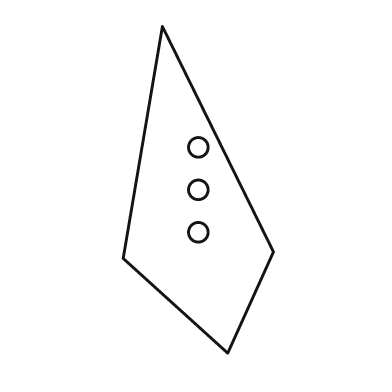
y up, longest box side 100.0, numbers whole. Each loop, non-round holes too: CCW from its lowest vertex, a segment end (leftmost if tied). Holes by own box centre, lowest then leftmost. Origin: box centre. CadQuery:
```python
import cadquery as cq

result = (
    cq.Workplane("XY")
    .moveTo(9.0, -50.0)
    .lineTo(23.0, -19.0)
    .lineTo(-11.0, 50.0)
    .lineTo(-23.0, -21.0)
    .close()
    .moveTo(0.0, -13.0)
    .circle(3.0)
    .moveTo(0.0, 0.0)
    .circle(3.0)
    .moveTo(0.0, 13.0)
    .circle(3.0)
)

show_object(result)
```